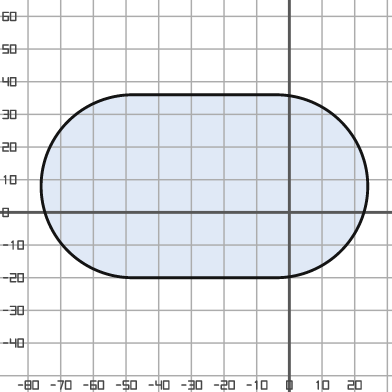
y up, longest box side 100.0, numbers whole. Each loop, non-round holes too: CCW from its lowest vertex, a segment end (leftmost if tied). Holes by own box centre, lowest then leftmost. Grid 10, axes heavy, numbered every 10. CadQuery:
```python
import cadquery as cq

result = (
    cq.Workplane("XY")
    .moveTo(-48.0, -20.0)
    .lineTo(-4.0, -20.0)
    .threePointArc((24.0, 8.0), (-4.0, 36.0))
    .lineTo(-48.0, 36.0)
    .threePointArc((-76.0, 8.0), (-48.0, -20.0))
    .close()
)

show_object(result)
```